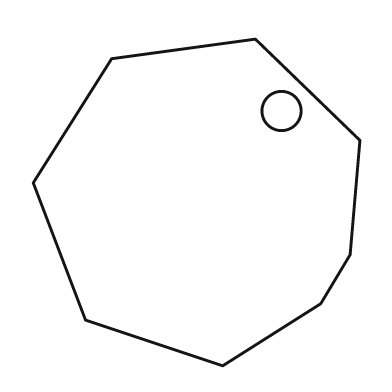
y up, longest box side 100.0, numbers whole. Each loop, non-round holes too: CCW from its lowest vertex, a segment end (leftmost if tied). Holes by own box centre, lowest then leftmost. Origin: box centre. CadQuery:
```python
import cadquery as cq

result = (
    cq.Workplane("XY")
    .moveTo(8.0, -50.0)
    .lineTo(38.0, -31.0)
    .lineTo(47.0, -16.0)
    .lineTo(50.0, 19.0)
    .lineTo(18.0, 50.0)
    .lineTo(-26.0, 44.0)
    .lineTo(-50.0, 6.0)
    .lineTo(-34.0, -36.0)
    .close()
    .moveTo(26.0, 28.0)
    .circle(6.0)
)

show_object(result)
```